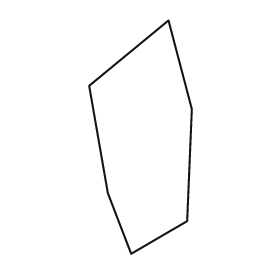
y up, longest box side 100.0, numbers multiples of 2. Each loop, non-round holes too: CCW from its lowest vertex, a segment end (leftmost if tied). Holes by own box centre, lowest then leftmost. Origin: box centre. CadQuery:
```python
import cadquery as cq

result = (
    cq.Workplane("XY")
    .moveTo(-4.0, -50.0)
    .lineTo(20.0, -36.0)
    .lineTo(22.0, 12.0)
    .lineTo(12.0, 50.0)
    .lineTo(-22.0, 22.0)
    .lineTo(-14.0, -24.0)
    .close()
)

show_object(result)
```